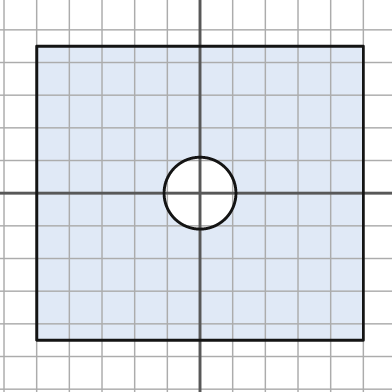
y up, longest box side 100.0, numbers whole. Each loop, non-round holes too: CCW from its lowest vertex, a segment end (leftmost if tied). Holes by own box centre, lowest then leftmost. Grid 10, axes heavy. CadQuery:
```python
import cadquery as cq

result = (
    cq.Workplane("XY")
    .moveTo(-50.0, -45.0)
    .lineTo(50.0, -45.0)
    .lineTo(50.0, 45.0)
    .lineTo(-50.0, 45.0)
    .close()
    .moveTo(0.0, 0.0)
    .circle(11.0)
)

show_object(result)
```